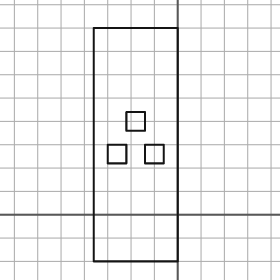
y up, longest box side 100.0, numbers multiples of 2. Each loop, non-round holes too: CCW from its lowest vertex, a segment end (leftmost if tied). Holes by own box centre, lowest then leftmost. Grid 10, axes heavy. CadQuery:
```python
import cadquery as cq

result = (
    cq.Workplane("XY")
    .moveTo(-36.0, -20.0)
    .lineTo(0.0, -20.0)
    .lineTo(0.0, 80.0)
    .lineTo(-36.0, 80.0)
    .close()
    .moveTo(-30.0, 22.0)
    .lineTo(-22.0, 22.0)
    .lineTo(-22.0, 30.0)
    .lineTo(-30.0, 30.0)
    .close()
    .moveTo(-14.0, 22.0)
    .lineTo(-6.0, 22.0)
    .lineTo(-6.0, 30.0)
    .lineTo(-14.0, 30.0)
    .close()
    .moveTo(-22.0, 36.0)
    .lineTo(-14.0, 36.0)
    .lineTo(-14.0, 44.0)
    .lineTo(-22.0, 44.0)
    .close()
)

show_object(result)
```